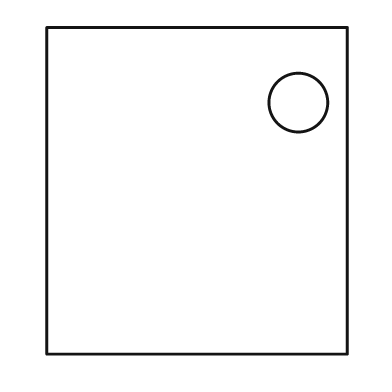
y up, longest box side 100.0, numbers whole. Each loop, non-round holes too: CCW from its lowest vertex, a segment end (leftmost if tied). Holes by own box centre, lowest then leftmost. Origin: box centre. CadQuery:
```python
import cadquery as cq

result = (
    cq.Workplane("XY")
    .moveTo(-46.0, -50.0)
    .lineTo(46.0, -50.0)
    .lineTo(46.0, 50.0)
    .lineTo(-46.0, 50.0)
    .close()
    .moveTo(31.0, 27.0)
    .circle(9.0)
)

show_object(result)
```